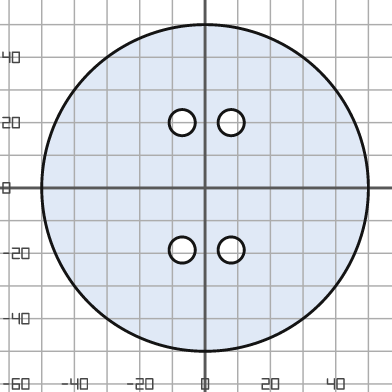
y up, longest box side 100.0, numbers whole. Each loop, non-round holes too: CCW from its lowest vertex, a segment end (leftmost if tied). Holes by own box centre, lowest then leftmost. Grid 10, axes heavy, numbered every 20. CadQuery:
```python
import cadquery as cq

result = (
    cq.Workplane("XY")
    .moveTo(0.0, 0.0)
    .circle(50.0)
    .moveTo(-7.0, -19.0)
    .circle(4.0)
    .moveTo(8.0, -19.0)
    .circle(4.0)
    .moveTo(-7.0, 20.0)
    .circle(4.0)
    .moveTo(8.0, 20.0)
    .circle(4.0)
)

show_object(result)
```